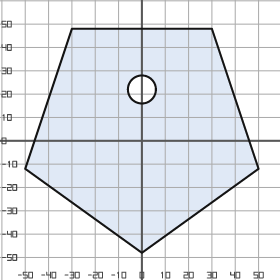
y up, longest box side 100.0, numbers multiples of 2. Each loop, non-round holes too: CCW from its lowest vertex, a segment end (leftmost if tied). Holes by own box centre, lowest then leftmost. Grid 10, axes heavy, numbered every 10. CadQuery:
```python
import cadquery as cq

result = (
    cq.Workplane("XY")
    .moveTo(0.0, -48.0)
    .lineTo(50.0, -12.0)
    .lineTo(30.0, 48.0)
    .lineTo(-30.0, 48.0)
    .lineTo(-50.0, -12.0)
    .close()
    .moveTo(0.0, 22.0)
    .circle(6.0)
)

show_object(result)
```